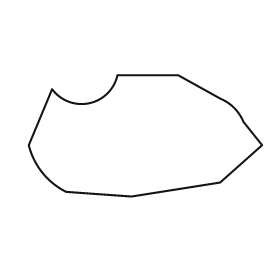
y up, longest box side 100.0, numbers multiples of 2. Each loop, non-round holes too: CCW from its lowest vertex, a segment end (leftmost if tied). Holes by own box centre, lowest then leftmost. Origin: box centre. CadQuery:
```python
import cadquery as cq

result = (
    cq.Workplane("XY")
    .moveTo(-6.0, -26.0)
    .lineTo(32.0, -20.0)
    .lineTo(50.0, -4.0)
    .lineTo(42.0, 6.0)
    .threePointArc((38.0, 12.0), (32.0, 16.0))
    .lineTo(14.0, 26.0)
    .lineTo(-12.0, 26.0)
    .threePointArc((-24.0, 14.0), (-40.0, 20.0))
    .lineTo(-50.0, -4.0)
    .threePointArc((-44.0, -16.0), (-34.0, -24.0))
    .close()
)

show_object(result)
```